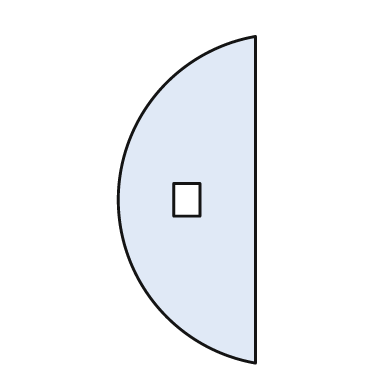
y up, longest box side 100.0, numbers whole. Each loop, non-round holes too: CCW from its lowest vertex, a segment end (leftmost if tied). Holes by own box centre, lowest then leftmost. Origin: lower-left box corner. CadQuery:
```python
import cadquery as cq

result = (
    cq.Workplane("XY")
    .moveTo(42.0, 0.0)
    .lineTo(42.0, 100.0)
    .threePointArc((0.0, 50.0), (42.0, 0.0))
    .close()
    .moveTo(17.0, 45.0)
    .lineTo(25.0, 45.0)
    .lineTo(25.0, 55.0)
    .lineTo(17.0, 55.0)
    .close()
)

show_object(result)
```